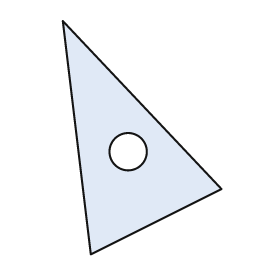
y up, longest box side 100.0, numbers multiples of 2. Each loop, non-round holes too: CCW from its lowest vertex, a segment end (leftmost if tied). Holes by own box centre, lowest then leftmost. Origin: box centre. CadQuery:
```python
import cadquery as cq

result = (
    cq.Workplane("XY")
    .moveTo(-22.0, -50.0)
    .lineTo(34.0, -22.0)
    .lineTo(-34.0, 50.0)
    .close()
    .moveTo(-6.0, -6.0)
    .circle(8.0)
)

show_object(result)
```